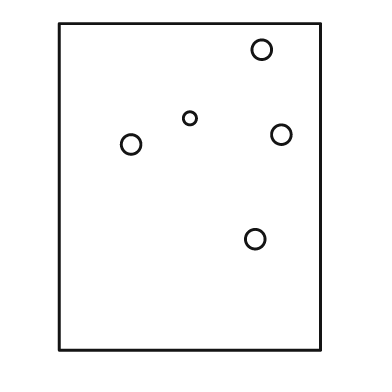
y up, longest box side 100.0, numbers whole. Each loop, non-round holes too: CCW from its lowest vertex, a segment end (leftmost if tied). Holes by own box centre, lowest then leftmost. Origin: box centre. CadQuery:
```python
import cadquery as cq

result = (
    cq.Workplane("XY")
    .moveTo(-40.0, -50.0)
    .lineTo(40.0, -50.0)
    .lineTo(40.0, 50.0)
    .lineTo(-40.0, 50.0)
    .close()
    .moveTo(20.0, -16.0)
    .circle(3.0)
    .moveTo(-18.0, 13.0)
    .circle(3.0)
    .moveTo(28.0, 16.0)
    .circle(3.0)
    .moveTo(0.0, 21.0)
    .circle(2.0)
    .moveTo(22.0, 42.0)
    .circle(3.0)
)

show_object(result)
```